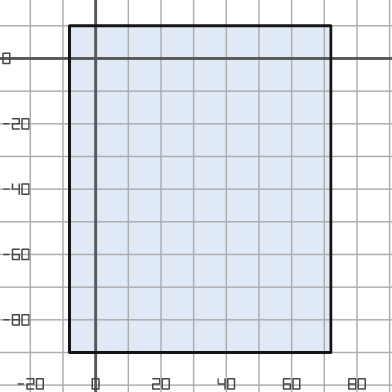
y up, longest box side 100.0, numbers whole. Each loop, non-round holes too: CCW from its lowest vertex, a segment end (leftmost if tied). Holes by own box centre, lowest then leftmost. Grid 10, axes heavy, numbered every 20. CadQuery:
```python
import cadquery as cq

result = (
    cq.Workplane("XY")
    .moveTo(-8.0, -90.0)
    .lineTo(72.0, -90.0)
    .lineTo(72.0, 10.0)
    .lineTo(-8.0, 10.0)
    .close()
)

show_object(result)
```